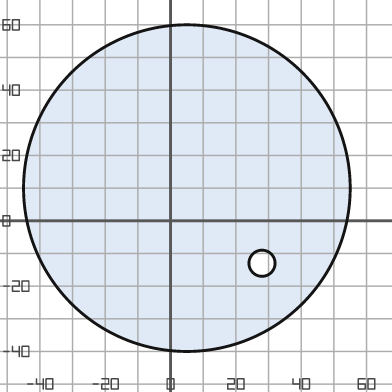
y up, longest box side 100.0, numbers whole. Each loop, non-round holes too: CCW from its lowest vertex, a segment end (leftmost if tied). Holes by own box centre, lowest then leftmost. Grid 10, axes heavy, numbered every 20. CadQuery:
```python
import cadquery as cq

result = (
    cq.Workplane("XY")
    .moveTo(5.0, 10.0)
    .circle(50.0)
    .moveTo(28.0, -13.0)
    .circle(4.0)
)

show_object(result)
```